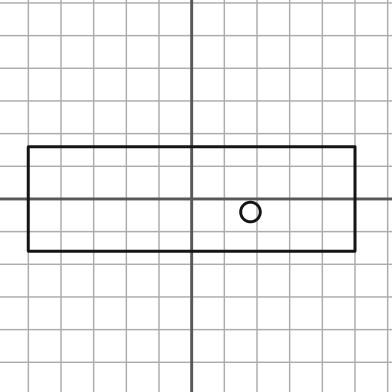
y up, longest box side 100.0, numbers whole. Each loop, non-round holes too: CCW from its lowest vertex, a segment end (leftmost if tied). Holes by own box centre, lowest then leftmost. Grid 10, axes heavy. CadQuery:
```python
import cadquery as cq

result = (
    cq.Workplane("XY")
    .moveTo(-50.0, -16.0)
    .lineTo(50.0, -16.0)
    .lineTo(50.0, 16.0)
    .lineTo(-50.0, 16.0)
    .close()
    .moveTo(18.0, -4.0)
    .circle(3.0)
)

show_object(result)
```